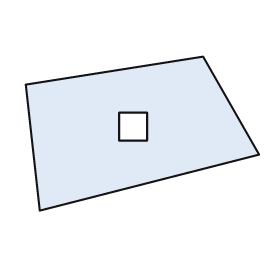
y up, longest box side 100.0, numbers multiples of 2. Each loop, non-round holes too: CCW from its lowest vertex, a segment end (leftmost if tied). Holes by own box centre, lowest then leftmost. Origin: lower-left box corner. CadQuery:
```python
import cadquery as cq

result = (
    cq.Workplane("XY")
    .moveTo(6.0, 0.0)
    .lineTo(100.0, 24.0)
    .lineTo(76.0, 66.0)
    .lineTo(0.0, 54.0)
    .close()
    .moveTo(40.0, 30.0)
    .lineTo(52.0, 30.0)
    .lineTo(52.0, 42.0)
    .lineTo(40.0, 42.0)
    .close()
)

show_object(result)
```